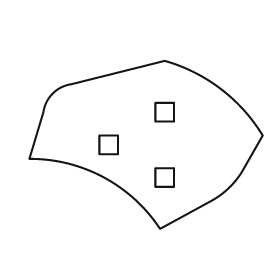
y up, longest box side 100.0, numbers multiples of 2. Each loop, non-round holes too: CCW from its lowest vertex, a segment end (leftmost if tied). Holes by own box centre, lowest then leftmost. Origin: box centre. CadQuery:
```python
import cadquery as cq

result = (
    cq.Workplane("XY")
    .moveTo(6.0, -36.0)
    .lineTo(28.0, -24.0)
    .threePointArc((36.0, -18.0), (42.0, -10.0))
    .lineTo(50.0, 4.0)
    .threePointArc((32.0, 24.0), (8.0, 36.0))
    .lineTo(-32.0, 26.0)
    .threePointArc((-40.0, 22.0), (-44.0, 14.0))
    .lineTo(-50.0, -6.0)
    .threePointArc((-18.0, -14.0), (6.0, -36.0))
    .close()
    .moveTo(4.0, -18.0)
    .lineTo(12.0, -18.0)
    .lineTo(12.0, -10.0)
    .lineTo(4.0, -10.0)
    .close()
    .moveTo(-20.0, -4.0)
    .lineTo(-12.0, -4.0)
    .lineTo(-12.0, 4.0)
    .lineTo(-20.0, 4.0)
    .close()
    .moveTo(4.0, 10.0)
    .lineTo(12.0, 10.0)
    .lineTo(12.0, 18.0)
    .lineTo(4.0, 18.0)
    .close()
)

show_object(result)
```